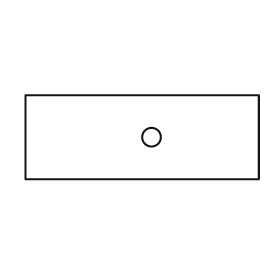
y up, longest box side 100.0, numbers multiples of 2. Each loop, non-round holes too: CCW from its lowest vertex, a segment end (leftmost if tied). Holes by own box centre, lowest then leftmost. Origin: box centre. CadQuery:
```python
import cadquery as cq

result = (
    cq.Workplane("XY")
    .moveTo(-50.0, -18.0)
    .lineTo(50.0, -18.0)
    .lineTo(50.0, 18.0)
    .lineTo(-50.0, 18.0)
    .close()
    .moveTo(4.0, 0.0)
    .circle(4.0)
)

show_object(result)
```